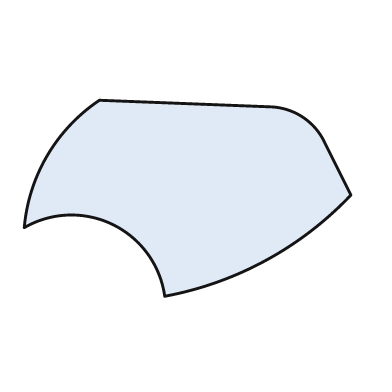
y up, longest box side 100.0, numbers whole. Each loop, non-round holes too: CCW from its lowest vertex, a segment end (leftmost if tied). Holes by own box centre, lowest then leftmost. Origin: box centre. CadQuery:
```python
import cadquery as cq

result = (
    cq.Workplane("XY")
    .moveTo(-7.0, -30.0)
    .threePointArc((24.0, -19.0), (50.0, 1.0))
    .lineTo(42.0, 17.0)
    .threePointArc((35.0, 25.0), (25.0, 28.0))
    .lineTo(-27.0, 30.0)
    .threePointArc((-43.0, 13.0), (-50.0, -9.0))
    .threePointArc((-23.0, -8.0), (-7.0, -30.0))
    .close()
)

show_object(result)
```